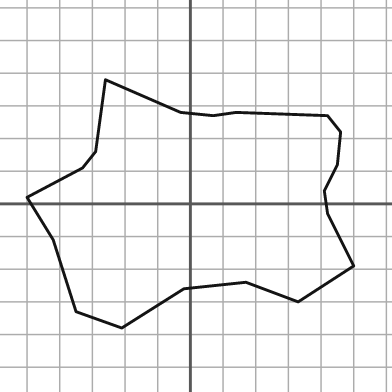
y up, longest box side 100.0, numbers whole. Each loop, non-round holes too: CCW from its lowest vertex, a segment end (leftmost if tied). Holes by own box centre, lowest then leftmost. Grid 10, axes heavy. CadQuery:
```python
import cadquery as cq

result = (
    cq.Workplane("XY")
    .moveTo(-21.0, -38.0)
    .lineTo(-2.0, -26.0)
    .lineTo(17.0, -24.0)
    .lineTo(33.0, -30.0)
    .lineTo(50.0, -19.0)
    .lineTo(42.0, -3.0)
    .lineTo(41.0, 4.0)
    .lineTo(45.0, 12.0)
    .lineTo(46.0, 22.0)
    .lineTo(42.0, 27.0)
    .lineTo(14.0, 28.0)
    .lineTo(7.0, 27.0)
    .lineTo(-3.0, 28.0)
    .lineTo(-26.0, 38.0)
    .lineTo(-29.0, 16.0)
    .lineTo(-33.0, 11.0)
    .lineTo(-50.0, 2.0)
    .lineTo(-42.0, -11.0)
    .lineTo(-35.0, -33.0)
    .close()
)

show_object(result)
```